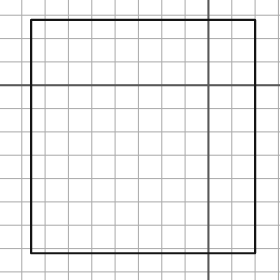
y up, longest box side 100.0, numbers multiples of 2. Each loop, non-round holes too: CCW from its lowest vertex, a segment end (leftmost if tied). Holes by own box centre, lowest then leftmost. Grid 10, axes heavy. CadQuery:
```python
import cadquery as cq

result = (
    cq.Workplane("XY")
    .moveTo(-76.0, -72.0)
    .lineTo(20.0, -72.0)
    .lineTo(20.0, 28.0)
    .lineTo(-76.0, 28.0)
    .close()
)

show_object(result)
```